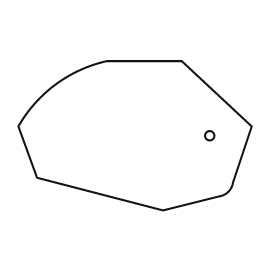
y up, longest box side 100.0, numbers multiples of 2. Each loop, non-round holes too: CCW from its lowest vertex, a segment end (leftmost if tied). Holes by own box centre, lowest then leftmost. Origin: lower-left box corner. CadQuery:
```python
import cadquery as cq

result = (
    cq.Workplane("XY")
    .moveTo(62.0, 0.0)
    .lineTo(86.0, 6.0)
    .threePointArc((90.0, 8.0), (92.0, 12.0))
    .lineTo(100.0, 36.0)
    .lineTo(70.0, 64.0)
    .lineTo(38.0, 64.0)
    .threePointArc((16.0, 54.0), (0.0, 36.0))
    .lineTo(8.0, 14.0)
    .close()
    .moveTo(82.0, 32.0)
    .circle(2.0)
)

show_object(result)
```